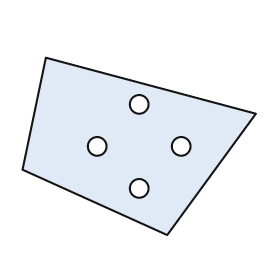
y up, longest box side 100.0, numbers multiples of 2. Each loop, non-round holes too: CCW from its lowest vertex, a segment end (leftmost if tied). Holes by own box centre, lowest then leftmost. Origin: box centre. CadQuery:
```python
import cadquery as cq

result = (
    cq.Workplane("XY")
    .moveTo(12.0, -38.0)
    .lineTo(50.0, 14.0)
    .lineTo(-40.0, 38.0)
    .lineTo(-50.0, -10.0)
    .close()
    .moveTo(0.0, -18.0)
    .circle(4.0)
    .moveTo(-18.0, 0.0)
    .circle(4.0)
    .moveTo(18.0, 0.0)
    .circle(4.0)
    .moveTo(0.0, 18.0)
    .circle(4.0)
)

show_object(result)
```